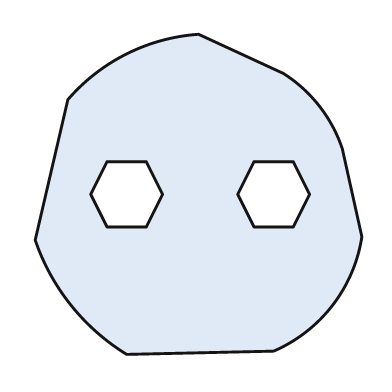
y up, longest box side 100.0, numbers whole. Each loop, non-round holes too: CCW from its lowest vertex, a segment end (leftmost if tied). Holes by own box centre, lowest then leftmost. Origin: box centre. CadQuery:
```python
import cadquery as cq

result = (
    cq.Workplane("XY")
    .moveTo(-22.0, -49.0)
    .lineTo(23.0, -48.0)
    .threePointArc((41.0, -34.0), (50.0, -13.0))
    .lineTo(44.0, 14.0)
    .threePointArc((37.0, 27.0), (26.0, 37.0))
    .lineTo(0.0, 49.0)
    .threePointArc((-22.0, 43.0), (-40.0, 29.0))
    .lineTo(-50.0, -14.0)
    .threePointArc((-39.0, -34.0), (-22.0, -49.0))
    .close()
    .moveTo(-28.0, -10.0)
    .lineTo(-16.0, -10.0)
    .lineTo(-11.0, 0.0)
    .lineTo(-16.0, 10.0)
    .lineTo(-28.0, 10.0)
    .lineTo(-33.0, 0.0)
    .close()
    .moveTo(17.0, -10.0)
    .lineTo(29.0, -10.0)
    .lineTo(34.0, 0.0)
    .lineTo(29.0, 10.0)
    .lineTo(17.0, 10.0)
    .lineTo(12.0, 0.0)
    .close()
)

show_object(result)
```